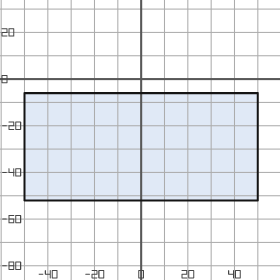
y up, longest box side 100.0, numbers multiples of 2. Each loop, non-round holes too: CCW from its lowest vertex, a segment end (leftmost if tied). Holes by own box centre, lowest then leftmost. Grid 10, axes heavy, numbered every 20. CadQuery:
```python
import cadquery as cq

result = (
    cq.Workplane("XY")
    .moveTo(-50.0, -52.0)
    .lineTo(50.0, -52.0)
    .lineTo(50.0, -6.0)
    .lineTo(-50.0, -6.0)
    .close()
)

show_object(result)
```